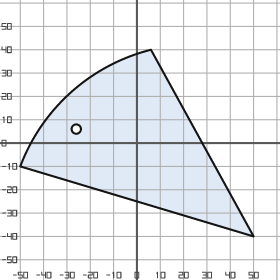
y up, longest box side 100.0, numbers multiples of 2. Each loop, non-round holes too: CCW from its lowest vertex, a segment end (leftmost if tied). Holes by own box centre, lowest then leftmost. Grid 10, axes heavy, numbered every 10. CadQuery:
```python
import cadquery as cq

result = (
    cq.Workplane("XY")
    .moveTo(50.0, -40.0)
    .lineTo(6.0, 40.0)
    .threePointArc((-28.0, 22.0), (-50.0, -10.0))
    .close()
    .moveTo(-26.0, 6.0)
    .circle(2.0)
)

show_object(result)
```